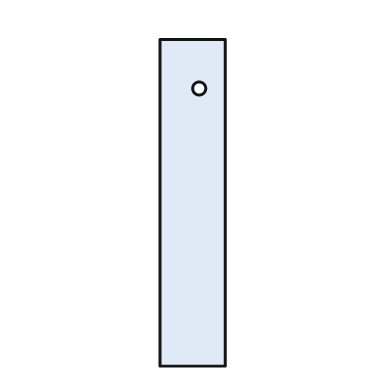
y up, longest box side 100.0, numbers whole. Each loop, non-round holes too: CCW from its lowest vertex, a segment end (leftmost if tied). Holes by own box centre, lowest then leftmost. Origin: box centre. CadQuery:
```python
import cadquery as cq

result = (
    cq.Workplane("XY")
    .moveTo(-10.0, -50.0)
    .lineTo(10.0, -50.0)
    .lineTo(10.0, 50.0)
    .lineTo(-10.0, 50.0)
    .close()
    .moveTo(2.0, 35.0)
    .circle(2.0)
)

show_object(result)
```